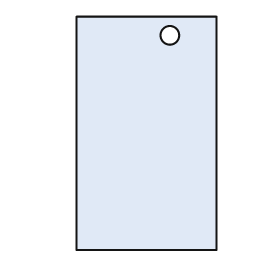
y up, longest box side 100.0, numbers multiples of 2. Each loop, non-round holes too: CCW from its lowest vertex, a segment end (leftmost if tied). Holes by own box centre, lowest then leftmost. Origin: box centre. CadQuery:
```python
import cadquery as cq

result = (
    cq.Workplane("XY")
    .moveTo(-30.0, -50.0)
    .lineTo(30.0, -50.0)
    .lineTo(30.0, 50.0)
    .lineTo(-30.0, 50.0)
    .close()
    .moveTo(10.0, 42.0)
    .circle(4.0)
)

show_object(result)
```